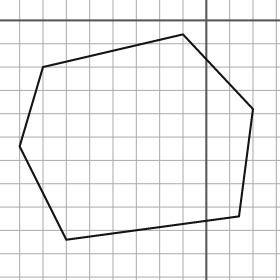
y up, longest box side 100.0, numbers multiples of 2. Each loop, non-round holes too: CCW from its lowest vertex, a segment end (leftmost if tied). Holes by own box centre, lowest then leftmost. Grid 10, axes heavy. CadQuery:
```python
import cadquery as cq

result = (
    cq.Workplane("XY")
    .moveTo(-60.0, -94.0)
    .lineTo(14.0, -84.0)
    .lineTo(20.0, -38.0)
    .lineTo(-10.0, -6.0)
    .lineTo(-70.0, -20.0)
    .lineTo(-80.0, -54.0)
    .close()
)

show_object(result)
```